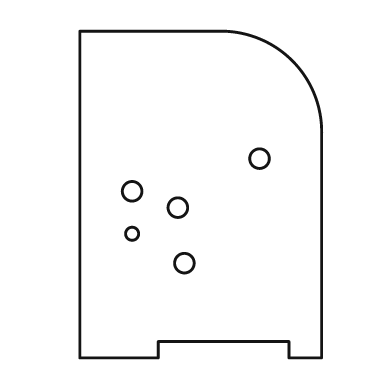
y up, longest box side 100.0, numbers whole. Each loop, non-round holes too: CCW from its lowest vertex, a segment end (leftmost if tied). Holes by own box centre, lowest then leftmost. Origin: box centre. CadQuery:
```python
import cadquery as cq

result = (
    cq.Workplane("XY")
    .moveTo(-37.0, -50.0)
    .lineTo(-13.0, -50.0)
    .lineTo(-13.0, -45.0)
    .lineTo(27.0, -45.0)
    .lineTo(27.0, -50.0)
    .lineTo(37.0, -50.0)
    .lineTo(37.0, 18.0)
    .threePointArc((28.0, 41.0), (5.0, 50.0))
    .lineTo(-37.0, 50.0)
    .close()
    .moveTo(-5.0, -21.0)
    .circle(3.0)
    .moveTo(-21.0, -12.0)
    .circle(2.0)
    .moveTo(-7.0, -4.0)
    .circle(3.0)
    .moveTo(-21.0, 1.0)
    .circle(3.0)
    .moveTo(18.0, 11.0)
    .circle(3.0)
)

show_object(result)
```